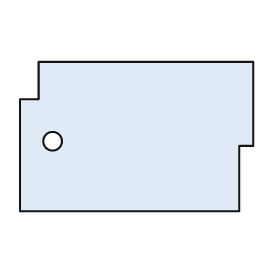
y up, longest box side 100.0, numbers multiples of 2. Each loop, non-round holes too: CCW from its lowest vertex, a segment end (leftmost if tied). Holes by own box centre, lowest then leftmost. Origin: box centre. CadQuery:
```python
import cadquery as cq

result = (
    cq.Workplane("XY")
    .moveTo(-50.0, -32.0)
    .lineTo(44.0, -32.0)
    .lineTo(44.0, -4.0)
    .lineTo(50.0, -4.0)
    .lineTo(50.0, 32.0)
    .lineTo(-42.0, 32.0)
    .lineTo(-42.0, 16.0)
    .lineTo(-50.0, 16.0)
    .close()
    .moveTo(-36.0, -2.0)
    .circle(4.0)
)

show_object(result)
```